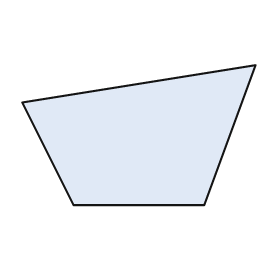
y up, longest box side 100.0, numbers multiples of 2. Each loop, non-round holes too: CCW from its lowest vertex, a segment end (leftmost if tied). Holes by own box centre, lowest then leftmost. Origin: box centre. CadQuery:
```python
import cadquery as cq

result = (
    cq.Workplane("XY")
    .moveTo(-28.0, -30.0)
    .lineTo(28.0, -30.0)
    .lineTo(50.0, 30.0)
    .lineTo(-50.0, 14.0)
    .close()
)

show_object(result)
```